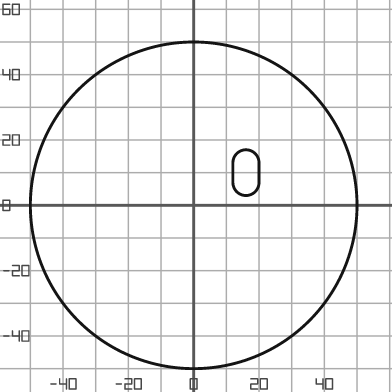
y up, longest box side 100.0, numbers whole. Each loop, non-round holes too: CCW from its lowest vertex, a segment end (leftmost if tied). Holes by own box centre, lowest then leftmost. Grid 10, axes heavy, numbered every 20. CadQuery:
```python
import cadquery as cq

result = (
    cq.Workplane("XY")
    .moveTo(0.0, 0.0)
    .circle(50.0)
    .moveTo(12.0, 7.0)
    .threePointArc((16.0, 3.0), (20.0, 7.0))
    .lineTo(20.0, 13.0)
    .threePointArc((16.0, 17.0), (12.0, 13.0))
    .close()
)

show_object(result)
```